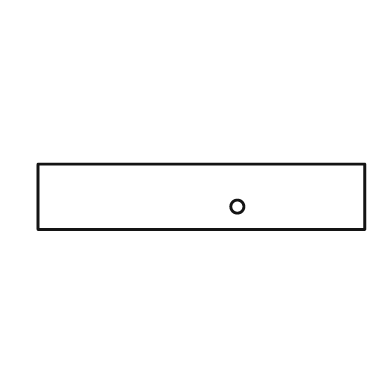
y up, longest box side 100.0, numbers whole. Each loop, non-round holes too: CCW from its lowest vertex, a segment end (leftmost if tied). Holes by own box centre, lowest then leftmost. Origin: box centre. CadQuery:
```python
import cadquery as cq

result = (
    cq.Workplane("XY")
    .moveTo(-50.0, -10.0)
    .lineTo(50.0, -10.0)
    .lineTo(50.0, 10.0)
    .lineTo(-50.0, 10.0)
    .close()
    .moveTo(11.0, -3.0)
    .circle(2.0)
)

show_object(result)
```